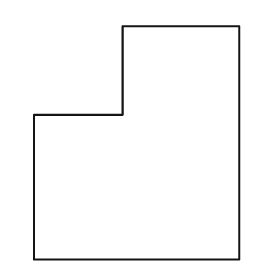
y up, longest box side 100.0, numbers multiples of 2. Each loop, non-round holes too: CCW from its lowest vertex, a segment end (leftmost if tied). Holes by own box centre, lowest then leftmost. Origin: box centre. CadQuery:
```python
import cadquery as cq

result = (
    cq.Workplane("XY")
    .moveTo(-44.0, -50.0)
    .lineTo(44.0, -50.0)
    .lineTo(44.0, 50.0)
    .lineTo(-6.0, 50.0)
    .lineTo(-6.0, 12.0)
    .lineTo(-44.0, 12.0)
    .close()
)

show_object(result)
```